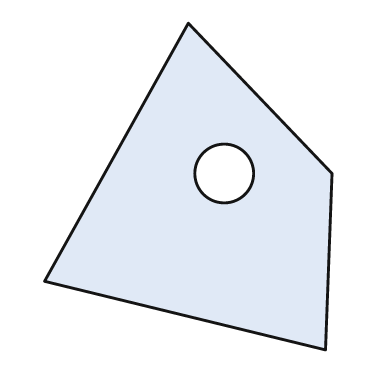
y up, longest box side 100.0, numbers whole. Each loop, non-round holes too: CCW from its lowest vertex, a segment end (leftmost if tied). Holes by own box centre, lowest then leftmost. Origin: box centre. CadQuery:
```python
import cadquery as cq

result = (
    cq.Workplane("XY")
    .moveTo(42.0, -50.0)
    .lineTo(44.0, 4.0)
    .lineTo(0.0, 50.0)
    .lineTo(-44.0, -29.0)
    .close()
    .moveTo(11.0, 4.0)
    .circle(9.0)
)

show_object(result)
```